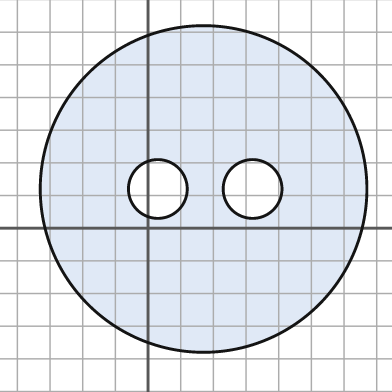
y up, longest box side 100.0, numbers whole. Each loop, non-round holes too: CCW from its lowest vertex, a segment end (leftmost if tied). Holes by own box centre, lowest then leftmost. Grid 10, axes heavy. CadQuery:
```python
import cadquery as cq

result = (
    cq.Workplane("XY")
    .moveTo(17.0, 12.0)
    .circle(50.0)
    .moveTo(3.0, 12.0)
    .circle(9.0)
    .moveTo(32.0, 12.0)
    .circle(9.0)
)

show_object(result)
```